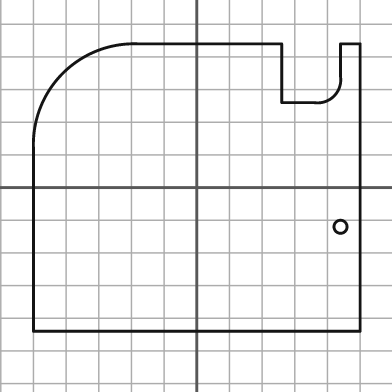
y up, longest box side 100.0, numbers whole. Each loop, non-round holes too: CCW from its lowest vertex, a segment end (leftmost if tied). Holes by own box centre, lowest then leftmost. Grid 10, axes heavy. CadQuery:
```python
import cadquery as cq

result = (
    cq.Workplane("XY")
    .moveTo(-50.0, -44.0)
    .lineTo(50.0, -44.0)
    .lineTo(50.0, 44.0)
    .lineTo(44.0, 44.0)
    .lineTo(44.0, 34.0)
    .threePointArc((42.0, 28.0), (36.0, 26.0))
    .lineTo(26.0, 26.0)
    .lineTo(26.0, 44.0)
    .lineTo(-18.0, 44.0)
    .threePointArc((-41.0, 35.0), (-50.0, 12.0))
    .close()
    .moveTo(44.0, -12.0)
    .circle(2.0)
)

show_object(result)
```